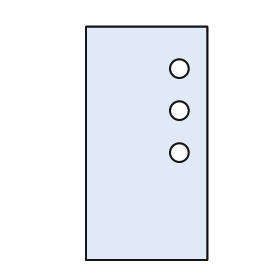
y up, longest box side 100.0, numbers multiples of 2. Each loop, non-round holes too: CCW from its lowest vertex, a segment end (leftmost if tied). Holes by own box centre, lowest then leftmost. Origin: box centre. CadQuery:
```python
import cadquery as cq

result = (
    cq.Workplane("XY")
    .moveTo(-26.0, -50.0)
    .lineTo(26.0, -50.0)
    .lineTo(26.0, 50.0)
    .lineTo(-26.0, 50.0)
    .close()
    .moveTo(14.0, -4.0)
    .circle(4.0)
    .moveTo(14.0, 14.0)
    .circle(4.0)
    .moveTo(14.0, 32.0)
    .circle(4.0)
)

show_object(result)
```